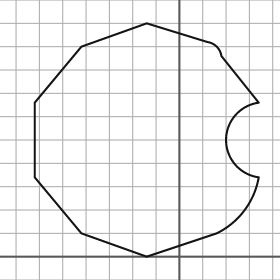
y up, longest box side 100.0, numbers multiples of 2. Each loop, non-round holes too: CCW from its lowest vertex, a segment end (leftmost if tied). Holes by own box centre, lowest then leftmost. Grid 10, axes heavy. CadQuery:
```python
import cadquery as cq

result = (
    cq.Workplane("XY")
    .moveTo(-14.0, 0.0)
    .lineTo(16.0, 10.0)
    .threePointArc((28.0, 20.0), (34.0, 34.0))
    .threePointArc((20.0, 50.0), (34.0, 66.0))
    .lineTo(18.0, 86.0)
    .threePointArc((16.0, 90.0), (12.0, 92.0))
    .lineTo(-14.0, 100.0)
    .lineTo(-42.0, 90.0)
    .lineTo(-62.0, 66.0)
    .lineTo(-62.0, 34.0)
    .lineTo(-42.0, 10.0)
    .close()
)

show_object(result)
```